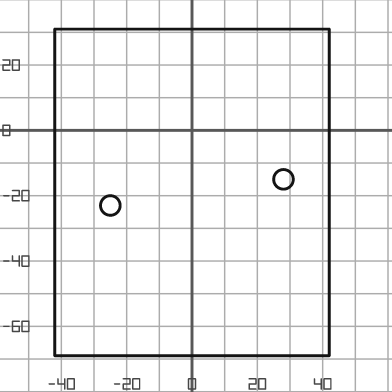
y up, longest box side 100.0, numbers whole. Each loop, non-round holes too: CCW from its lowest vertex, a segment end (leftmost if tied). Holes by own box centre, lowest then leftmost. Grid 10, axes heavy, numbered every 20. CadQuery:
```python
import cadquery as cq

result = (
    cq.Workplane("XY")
    .moveTo(-42.0, -69.0)
    .lineTo(42.0, -69.0)
    .lineTo(42.0, 31.0)
    .lineTo(-42.0, 31.0)
    .close()
    .moveTo(-25.0, -23.0)
    .circle(3.0)
    .moveTo(28.0, -15.0)
    .circle(3.0)
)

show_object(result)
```